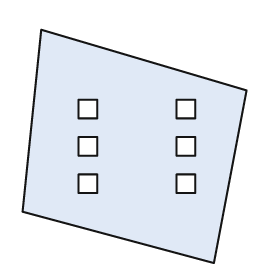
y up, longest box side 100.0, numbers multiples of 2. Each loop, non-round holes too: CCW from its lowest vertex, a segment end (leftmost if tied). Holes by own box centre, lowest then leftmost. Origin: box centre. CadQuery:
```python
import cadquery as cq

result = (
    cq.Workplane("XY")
    .moveTo(34.0, -50.0)
    .lineTo(48.0, 24.0)
    .lineTo(-40.0, 50.0)
    .lineTo(-48.0, -28.0)
    .close()
    .moveTo(-24.0, -20.0)
    .lineTo(-16.0, -20.0)
    .lineTo(-16.0, -12.0)
    .lineTo(-24.0, -12.0)
    .close()
    .moveTo(18.0, -20.0)
    .lineTo(26.0, -20.0)
    .lineTo(26.0, -12.0)
    .lineTo(18.0, -12.0)
    .close()
    .moveTo(-24.0, -4.0)
    .lineTo(-16.0, -4.0)
    .lineTo(-16.0, 4.0)
    .lineTo(-24.0, 4.0)
    .close()
    .moveTo(18.0, -4.0)
    .lineTo(26.0, -4.0)
    .lineTo(26.0, 4.0)
    .lineTo(18.0, 4.0)
    .close()
    .moveTo(-24.0, 12.0)
    .lineTo(-16.0, 12.0)
    .lineTo(-16.0, 20.0)
    .lineTo(-24.0, 20.0)
    .close()
    .moveTo(18.0, 12.0)
    .lineTo(26.0, 12.0)
    .lineTo(26.0, 20.0)
    .lineTo(18.0, 20.0)
    .close()
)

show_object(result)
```